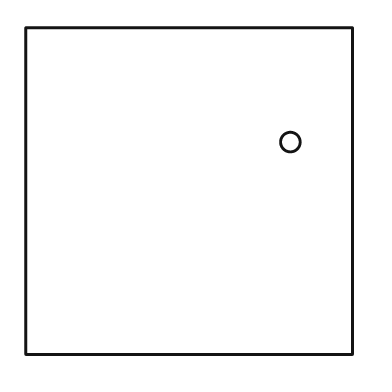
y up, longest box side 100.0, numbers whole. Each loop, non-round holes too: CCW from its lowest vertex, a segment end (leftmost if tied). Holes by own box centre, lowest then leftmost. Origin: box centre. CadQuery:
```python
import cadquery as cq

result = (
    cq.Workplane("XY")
    .moveTo(-50.0, -50.0)
    .lineTo(50.0, -50.0)
    .lineTo(50.0, 50.0)
    .lineTo(-50.0, 50.0)
    .close()
    .moveTo(31.0, 15.0)
    .circle(3.0)
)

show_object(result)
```